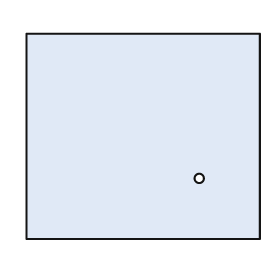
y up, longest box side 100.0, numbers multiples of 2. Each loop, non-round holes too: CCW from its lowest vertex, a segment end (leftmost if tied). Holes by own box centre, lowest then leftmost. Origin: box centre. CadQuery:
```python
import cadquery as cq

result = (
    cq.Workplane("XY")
    .moveTo(-50.0, -44.0)
    .lineTo(50.0, -44.0)
    .lineTo(50.0, 44.0)
    .lineTo(-50.0, 44.0)
    .close()
    .moveTo(24.0, -18.0)
    .circle(2.0)
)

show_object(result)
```